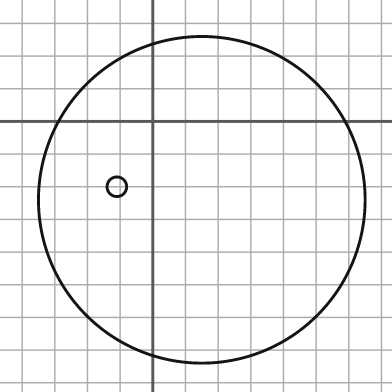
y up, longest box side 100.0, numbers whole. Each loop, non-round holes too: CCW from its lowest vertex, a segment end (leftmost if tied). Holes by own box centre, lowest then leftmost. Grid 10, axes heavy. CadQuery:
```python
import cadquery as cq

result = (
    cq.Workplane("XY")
    .moveTo(15.0, -24.0)
    .circle(50.0)
    .moveTo(-11.0, -20.0)
    .circle(3.0)
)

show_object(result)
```